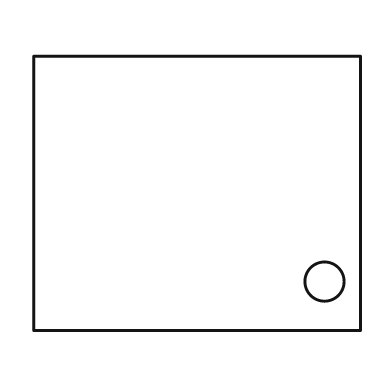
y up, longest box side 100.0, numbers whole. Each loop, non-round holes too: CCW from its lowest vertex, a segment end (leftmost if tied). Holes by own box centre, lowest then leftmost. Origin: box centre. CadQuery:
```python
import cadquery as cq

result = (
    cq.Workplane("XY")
    .moveTo(-50.0, -42.0)
    .lineTo(50.0, -42.0)
    .lineTo(50.0, 42.0)
    .lineTo(-50.0, 42.0)
    .close()
    .moveTo(39.0, -27.0)
    .circle(6.0)
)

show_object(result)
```